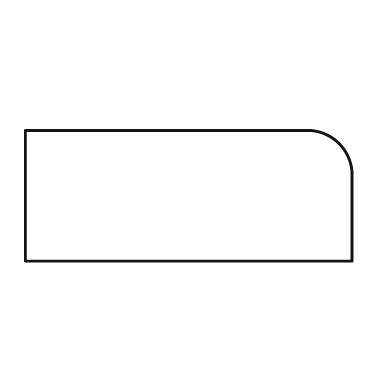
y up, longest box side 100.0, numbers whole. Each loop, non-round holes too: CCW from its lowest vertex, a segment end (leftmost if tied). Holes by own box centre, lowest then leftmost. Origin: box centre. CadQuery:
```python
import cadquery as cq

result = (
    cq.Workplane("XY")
    .moveTo(-50.0, -20.0)
    .lineTo(50.0, -20.0)
    .lineTo(50.0, 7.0)
    .threePointArc((46.0, 16.0), (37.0, 20.0))
    .lineTo(-50.0, 20.0)
    .close()
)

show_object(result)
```